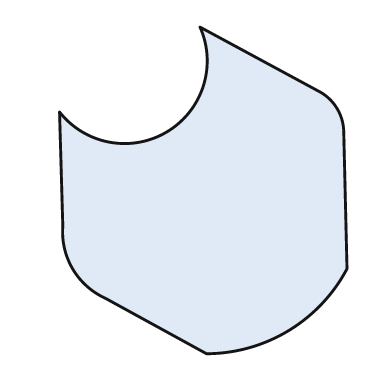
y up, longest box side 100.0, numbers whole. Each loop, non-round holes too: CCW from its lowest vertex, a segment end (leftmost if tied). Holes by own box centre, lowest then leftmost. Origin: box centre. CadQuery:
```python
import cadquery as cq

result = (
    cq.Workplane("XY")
    .moveTo(1.0, -50.0)
    .threePointArc((26.0, -43.0), (44.0, -24.0))
    .lineTo(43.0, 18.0)
    .threePointArc((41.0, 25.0), (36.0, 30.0))
    .lineTo(-1.0, 50.0)
    .threePointArc((-11.0, 18.0), (-44.0, 24.0))
    .lineTo(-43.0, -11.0)
    .threePointArc((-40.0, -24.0), (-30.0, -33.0))
    .close()
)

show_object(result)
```